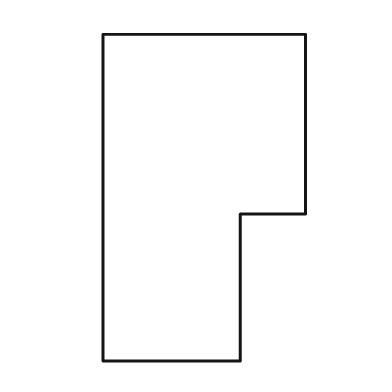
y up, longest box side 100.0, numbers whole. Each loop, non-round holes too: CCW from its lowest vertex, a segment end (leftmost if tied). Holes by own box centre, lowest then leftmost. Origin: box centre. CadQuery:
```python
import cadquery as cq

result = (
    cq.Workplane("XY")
    .moveTo(-31.0, -50.0)
    .lineTo(11.0, -50.0)
    .lineTo(11.0, -5.0)
    .lineTo(31.0, -5.0)
    .lineTo(31.0, 50.0)
    .lineTo(-31.0, 50.0)
    .close()
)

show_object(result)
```